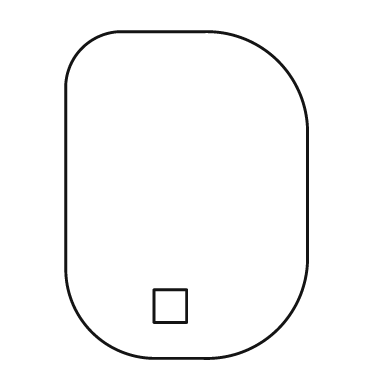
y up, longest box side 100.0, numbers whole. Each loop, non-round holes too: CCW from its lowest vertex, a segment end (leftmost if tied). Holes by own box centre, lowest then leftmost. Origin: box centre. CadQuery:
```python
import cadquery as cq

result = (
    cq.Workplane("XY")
    .moveTo(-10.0, -50.0)
    .lineTo(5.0, -50.0)
    .threePointArc((28.0, -41.0), (37.0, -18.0))
    .lineTo(37.0, 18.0)
    .threePointArc((28.0, 41.0), (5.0, 50.0))
    .lineTo(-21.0, 50.0)
    .threePointArc((-32.0, 45.0), (-37.0, 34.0))
    .lineTo(-37.0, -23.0)
    .threePointArc((-29.0, -42.0), (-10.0, -50.0))
    .close()
    .moveTo(-10.0, -39.0)
    .lineTo(0.0, -39.0)
    .lineTo(0.0, -29.0)
    .lineTo(-10.0, -29.0)
    .close()
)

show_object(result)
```